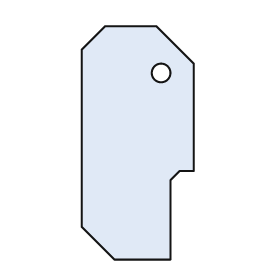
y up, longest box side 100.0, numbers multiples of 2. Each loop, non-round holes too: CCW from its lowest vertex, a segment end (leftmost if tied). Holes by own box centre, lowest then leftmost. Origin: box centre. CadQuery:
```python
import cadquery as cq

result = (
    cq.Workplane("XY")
    .moveTo(-10.0, -50.0)
    .lineTo(14.0, -50.0)
    .lineTo(14.0, -16.0)
    .lineTo(18.0, -12.0)
    .lineTo(24.0, -12.0)
    .lineTo(24.0, 34.0)
    .lineTo(8.0, 50.0)
    .lineTo(-14.0, 50.0)
    .lineTo(-24.0, 40.0)
    .lineTo(-24.0, -36.0)
    .close()
    .moveTo(10.0, 30.0)
    .circle(4.0)
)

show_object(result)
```